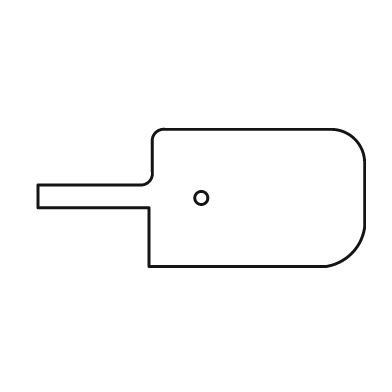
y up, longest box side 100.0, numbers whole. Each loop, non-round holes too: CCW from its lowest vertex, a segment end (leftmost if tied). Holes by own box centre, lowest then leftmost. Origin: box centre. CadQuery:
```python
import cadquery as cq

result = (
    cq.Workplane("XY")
    .moveTo(-16.0, -21.0)
    .lineTo(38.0, -21.0)
    .threePointArc((46.0, -17.0), (50.0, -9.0))
    .lineTo(50.0, 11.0)
    .threePointArc((47.0, 18.0), (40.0, 21.0))
    .lineTo(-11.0, 21.0)
    .threePointArc((-14.0, 20.0), (-15.0, 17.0))
    .lineTo(-15.0, 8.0)
    .threePointArc((-16.0, 5.0), (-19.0, 4.0))
    .lineTo(-50.0, 4.0)
    .lineTo(-50.0, -3.0)
    .lineTo(-16.0, -3.0)
    .close()
    .moveTo(0.0, 0.0)
    .circle(2.0)
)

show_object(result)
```